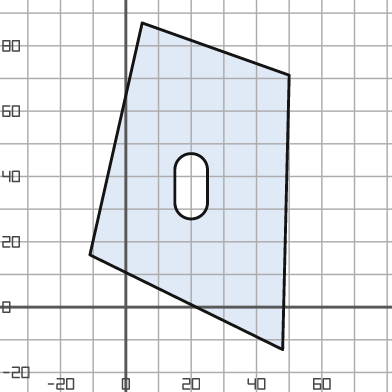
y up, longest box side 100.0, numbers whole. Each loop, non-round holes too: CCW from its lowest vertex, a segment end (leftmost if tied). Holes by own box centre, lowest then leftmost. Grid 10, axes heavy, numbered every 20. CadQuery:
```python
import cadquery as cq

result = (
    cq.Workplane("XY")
    .moveTo(48.0, -13.0)
    .lineTo(50.0, 71.0)
    .lineTo(5.0, 87.0)
    .lineTo(-11.0, 16.0)
    .close()
    .moveTo(15.0, 32.0)
    .threePointArc((20.0, 27.0), (25.0, 32.0))
    .lineTo(25.0, 42.0)
    .threePointArc((20.0, 47.0), (15.0, 42.0))
    .close()
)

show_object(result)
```